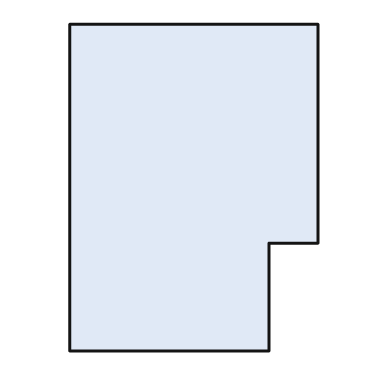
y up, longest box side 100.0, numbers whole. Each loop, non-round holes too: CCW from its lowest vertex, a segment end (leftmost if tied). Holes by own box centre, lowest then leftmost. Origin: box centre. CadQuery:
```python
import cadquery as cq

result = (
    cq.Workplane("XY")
    .moveTo(-38.0, -50.0)
    .lineTo(23.0, -50.0)
    .lineTo(23.0, -17.0)
    .lineTo(38.0, -17.0)
    .lineTo(38.0, 50.0)
    .lineTo(-38.0, 50.0)
    .close()
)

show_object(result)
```